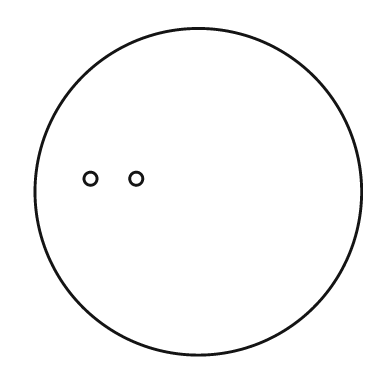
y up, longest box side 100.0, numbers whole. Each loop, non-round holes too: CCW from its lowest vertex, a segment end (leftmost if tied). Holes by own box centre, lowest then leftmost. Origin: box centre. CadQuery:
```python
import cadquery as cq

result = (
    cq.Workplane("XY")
    .moveTo(0.0, 0.0)
    .circle(50.0)
    .moveTo(-33.0, 4.0)
    .circle(2.0)
    .moveTo(-19.0, 4.0)
    .circle(2.0)
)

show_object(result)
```